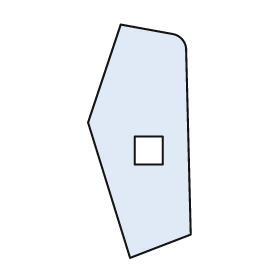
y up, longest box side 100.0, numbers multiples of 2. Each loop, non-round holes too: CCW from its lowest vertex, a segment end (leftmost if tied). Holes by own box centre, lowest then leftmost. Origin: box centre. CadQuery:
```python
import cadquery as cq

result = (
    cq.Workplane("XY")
    .moveTo(-4.0, -50.0)
    .lineTo(22.0, -40.0)
    .lineTo(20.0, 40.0)
    .threePointArc((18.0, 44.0), (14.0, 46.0))
    .lineTo(-8.0, 50.0)
    .lineTo(-22.0, 8.0)
    .close()
    .moveTo(-2.0, -10.0)
    .lineTo(10.0, -10.0)
    .lineTo(10.0, 2.0)
    .lineTo(-2.0, 2.0)
    .close()
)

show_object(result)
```